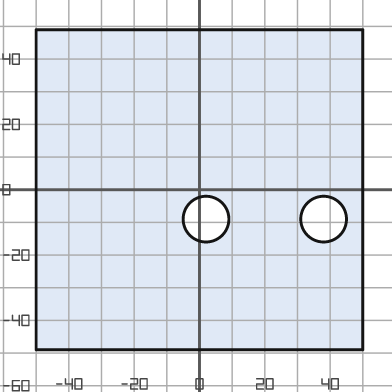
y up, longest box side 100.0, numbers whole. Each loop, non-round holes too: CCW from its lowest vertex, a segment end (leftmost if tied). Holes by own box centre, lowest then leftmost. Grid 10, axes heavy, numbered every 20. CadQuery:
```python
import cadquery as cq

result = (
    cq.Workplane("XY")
    .moveTo(-50.0, -49.0)
    .lineTo(50.0, -49.0)
    .lineTo(50.0, 49.0)
    .lineTo(-50.0, 49.0)
    .close()
    .moveTo(2.0, -9.0)
    .circle(7.0)
    .moveTo(38.0, -9.0)
    .circle(7.0)
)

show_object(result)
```